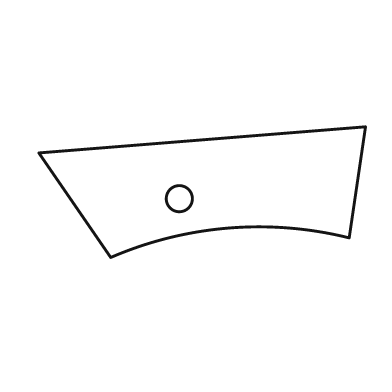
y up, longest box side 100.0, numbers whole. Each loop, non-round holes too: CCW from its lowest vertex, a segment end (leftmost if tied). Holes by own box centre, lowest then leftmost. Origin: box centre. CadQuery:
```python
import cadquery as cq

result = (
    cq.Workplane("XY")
    .moveTo(-28.0, -20.0)
    .threePointArc((8.0, -11.0), (45.0, -14.0))
    .lineTo(50.0, 20.0)
    .lineTo(-50.0, 12.0)
    .close()
    .moveTo(-7.0, -2.0)
    .circle(4.0)
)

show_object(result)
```